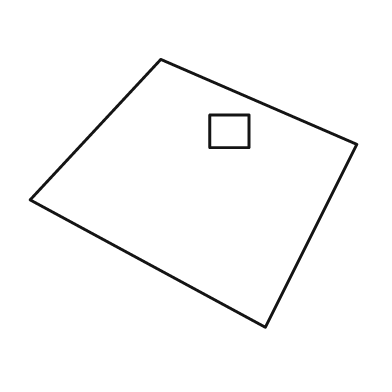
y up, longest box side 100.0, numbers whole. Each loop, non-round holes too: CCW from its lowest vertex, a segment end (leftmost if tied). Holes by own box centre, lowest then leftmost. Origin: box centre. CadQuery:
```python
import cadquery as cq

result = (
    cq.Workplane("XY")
    .moveTo(22.0, -41.0)
    .lineTo(50.0, 15.0)
    .lineTo(-10.0, 41.0)
    .lineTo(-50.0, -2.0)
    .close()
    .moveTo(5.0, 14.0)
    .lineTo(17.0, 14.0)
    .lineTo(17.0, 24.0)
    .lineTo(5.0, 24.0)
    .close()
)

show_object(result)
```